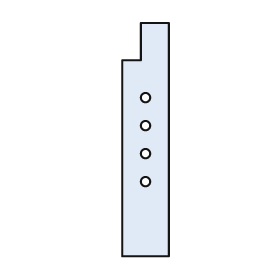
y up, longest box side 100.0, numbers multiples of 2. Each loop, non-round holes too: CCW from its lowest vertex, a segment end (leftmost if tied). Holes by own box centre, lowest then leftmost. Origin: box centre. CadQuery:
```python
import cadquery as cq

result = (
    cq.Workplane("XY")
    .moveTo(-10.0, -50.0)
    .lineTo(10.0, -50.0)
    .lineTo(10.0, 50.0)
    .lineTo(-2.0, 50.0)
    .lineTo(-2.0, 34.0)
    .lineTo(-10.0, 34.0)
    .close()
    .moveTo(0.0, -18.0)
    .circle(2.0)
    .moveTo(0.0, -6.0)
    .circle(2.0)
    .moveTo(0.0, 6.0)
    .circle(2.0)
    .moveTo(0.0, 18.0)
    .circle(2.0)
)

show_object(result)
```